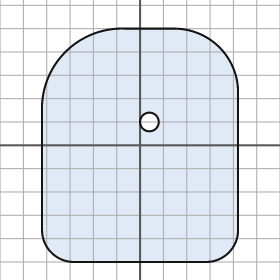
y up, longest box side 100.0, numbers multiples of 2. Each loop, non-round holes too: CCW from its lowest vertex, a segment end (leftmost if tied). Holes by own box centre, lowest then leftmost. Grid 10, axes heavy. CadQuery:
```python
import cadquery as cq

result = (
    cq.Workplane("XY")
    .moveTo(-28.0, -50.0)
    .lineTo(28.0, -50.0)
    .threePointArc((38.0, -46.0), (42.0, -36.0))
    .lineTo(42.0, 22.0)
    .threePointArc((34.0, 42.0), (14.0, 50.0))
    .lineTo(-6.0, 50.0)
    .threePointArc((-32.0, 40.0), (-42.0, 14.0))
    .lineTo(-42.0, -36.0)
    .threePointArc((-38.0, -46.0), (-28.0, -50.0))
    .close()
    .moveTo(4.0, 10.0)
    .circle(4.0)
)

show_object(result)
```